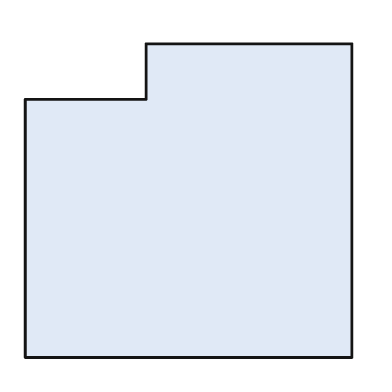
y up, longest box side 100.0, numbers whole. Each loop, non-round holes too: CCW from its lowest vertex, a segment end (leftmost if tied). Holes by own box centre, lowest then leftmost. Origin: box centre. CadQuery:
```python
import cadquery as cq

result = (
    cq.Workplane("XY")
    .moveTo(-50.0, -48.0)
    .lineTo(50.0, -48.0)
    .lineTo(50.0, 48.0)
    .lineTo(-13.0, 48.0)
    .lineTo(-13.0, 31.0)
    .lineTo(-50.0, 31.0)
    .close()
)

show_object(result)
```